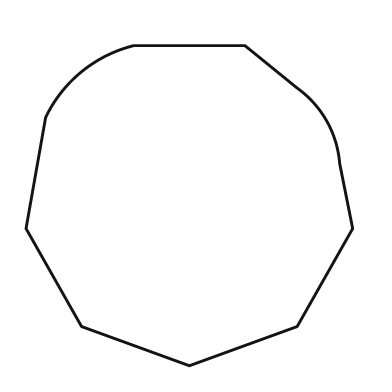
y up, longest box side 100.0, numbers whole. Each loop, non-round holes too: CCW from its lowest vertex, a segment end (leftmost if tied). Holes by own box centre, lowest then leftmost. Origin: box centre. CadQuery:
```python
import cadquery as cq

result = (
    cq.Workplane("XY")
    .moveTo(0.0, -49.0)
    .lineTo(33.0, -37.0)
    .lineTo(50.0, -7.0)
    .lineTo(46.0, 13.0)
    .threePointArc((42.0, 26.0), (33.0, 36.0))
    .lineTo(17.0, 49.0)
    .lineTo(-17.0, 49.0)
    .threePointArc((-33.0, 41.0), (-44.0, 27.0))
    .lineTo(-50.0, -7.0)
    .lineTo(-33.0, -37.0)
    .close()
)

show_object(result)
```